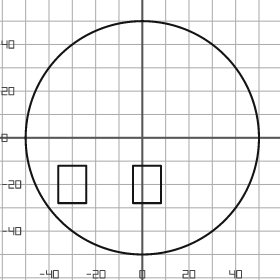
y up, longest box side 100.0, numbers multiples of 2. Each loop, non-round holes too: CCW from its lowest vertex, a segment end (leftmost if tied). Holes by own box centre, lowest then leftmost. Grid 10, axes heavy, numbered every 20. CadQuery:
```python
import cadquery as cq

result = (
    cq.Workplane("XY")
    .moveTo(0.0, 0.0)
    .circle(50.0)
    .moveTo(-36.0, -28.0)
    .lineTo(-24.0, -28.0)
    .lineTo(-24.0, -12.0)
    .lineTo(-36.0, -12.0)
    .close()
    .moveTo(-4.0, -28.0)
    .lineTo(8.0, -28.0)
    .lineTo(8.0, -12.0)
    .lineTo(-4.0, -12.0)
    .close()
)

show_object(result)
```